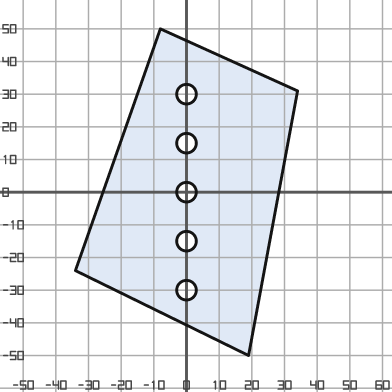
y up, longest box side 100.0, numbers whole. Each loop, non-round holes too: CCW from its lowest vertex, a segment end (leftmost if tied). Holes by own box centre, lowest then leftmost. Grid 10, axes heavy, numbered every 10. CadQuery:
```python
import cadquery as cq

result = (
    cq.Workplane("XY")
    .moveTo(19.0, -50.0)
    .lineTo(34.0, 31.0)
    .lineTo(-8.0, 50.0)
    .lineTo(-34.0, -24.0)
    .close()
    .moveTo(0.0, -30.0)
    .circle(3.0)
    .moveTo(0.0, -15.0)
    .circle(3.0)
    .moveTo(0.0, 0.0)
    .circle(3.0)
    .moveTo(0.0, 15.0)
    .circle(3.0)
    .moveTo(0.0, 30.0)
    .circle(3.0)
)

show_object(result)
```